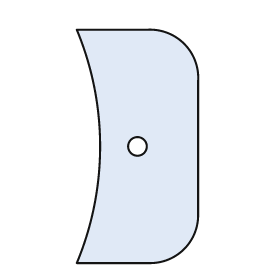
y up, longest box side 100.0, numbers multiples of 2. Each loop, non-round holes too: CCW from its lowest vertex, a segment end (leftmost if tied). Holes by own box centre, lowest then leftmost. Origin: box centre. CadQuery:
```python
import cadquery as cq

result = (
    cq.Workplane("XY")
    .moveTo(-26.0, -50.0)
    .lineTo(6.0, -50.0)
    .threePointArc((20.0, -44.0), (26.0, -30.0))
    .lineTo(26.0, 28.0)
    .threePointArc((20.0, 44.0), (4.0, 50.0))
    .lineTo(-26.0, 50.0)
    .threePointArc((-16.0, 0.0), (-26.0, -50.0))
    .close()
    .moveTo(0.0, 0.0)
    .circle(4.0)
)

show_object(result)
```